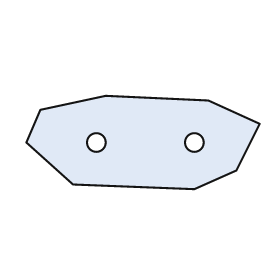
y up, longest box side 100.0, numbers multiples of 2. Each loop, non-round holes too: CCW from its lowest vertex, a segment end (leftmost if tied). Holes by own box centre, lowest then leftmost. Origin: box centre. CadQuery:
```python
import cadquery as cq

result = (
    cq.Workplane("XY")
    .moveTo(22.0, -20.0)
    .lineTo(40.0, -12.0)
    .lineTo(50.0, 8.0)
    .lineTo(28.0, 18.0)
    .lineTo(-16.0, 20.0)
    .lineTo(-44.0, 14.0)
    .lineTo(-50.0, 0.0)
    .lineTo(-30.0, -18.0)
    .close()
    .moveTo(-20.0, 0.0)
    .circle(4.0)
    .moveTo(22.0, 0.0)
    .circle(4.0)
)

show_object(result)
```